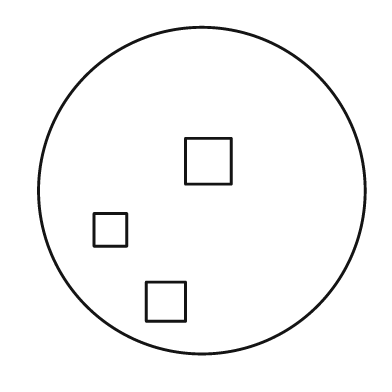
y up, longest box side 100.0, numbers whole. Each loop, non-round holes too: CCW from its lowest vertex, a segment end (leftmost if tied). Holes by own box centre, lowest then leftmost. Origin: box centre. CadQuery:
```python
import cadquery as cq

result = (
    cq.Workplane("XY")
    .moveTo(0.0, 0.0)
    .circle(50.0)
    .moveTo(-17.0, -40.0)
    .lineTo(-5.0, -40.0)
    .lineTo(-5.0, -28.0)
    .lineTo(-17.0, -28.0)
    .close()
    .moveTo(-33.0, -17.0)
    .lineTo(-23.0, -17.0)
    .lineTo(-23.0, -7.0)
    .lineTo(-33.0, -7.0)
    .close()
    .moveTo(-5.0, 2.0)
    .lineTo(9.0, 2.0)
    .lineTo(9.0, 16.0)
    .lineTo(-5.0, 16.0)
    .close()
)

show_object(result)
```